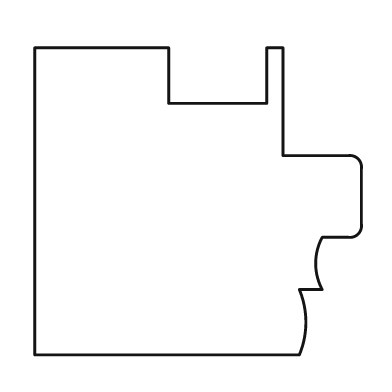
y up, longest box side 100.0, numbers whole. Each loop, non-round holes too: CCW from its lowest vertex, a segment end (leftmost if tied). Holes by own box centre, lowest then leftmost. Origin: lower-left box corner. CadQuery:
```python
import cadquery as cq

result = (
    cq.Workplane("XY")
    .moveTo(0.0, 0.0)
    .lineTo(81.0, 0.0)
    .threePointArc((83.0, 10.0), (81.0, 20.0))
    .lineTo(88.0, 20.0)
    .threePointArc((86.0, 28.0), (88.0, 36.0))
    .lineTo(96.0, 36.0)
    .threePointArc((99.0, 37.0), (100.0, 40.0))
    .lineTo(100.0, 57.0)
    .threePointArc((99.0, 60.0), (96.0, 61.0))
    .lineTo(76.0, 61.0)
    .lineTo(76.0, 94.0)
    .lineTo(71.0, 94.0)
    .lineTo(71.0, 77.0)
    .lineTo(41.0, 77.0)
    .lineTo(41.0, 94.0)
    .lineTo(0.0, 94.0)
    .close()
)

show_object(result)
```